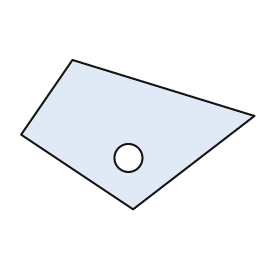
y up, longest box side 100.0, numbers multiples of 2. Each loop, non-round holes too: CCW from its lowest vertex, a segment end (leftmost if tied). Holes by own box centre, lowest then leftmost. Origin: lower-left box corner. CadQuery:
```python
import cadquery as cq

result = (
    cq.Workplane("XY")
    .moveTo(48.0, 0.0)
    .lineTo(100.0, 40.0)
    .lineTo(22.0, 64.0)
    .lineTo(0.0, 32.0)
    .close()
    .moveTo(46.0, 22.0)
    .circle(6.0)
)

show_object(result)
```